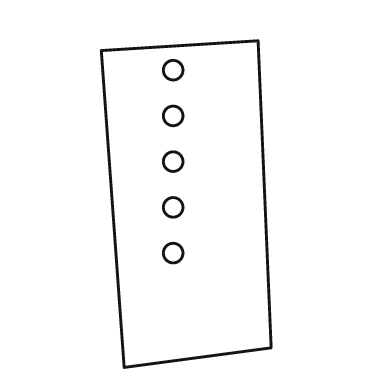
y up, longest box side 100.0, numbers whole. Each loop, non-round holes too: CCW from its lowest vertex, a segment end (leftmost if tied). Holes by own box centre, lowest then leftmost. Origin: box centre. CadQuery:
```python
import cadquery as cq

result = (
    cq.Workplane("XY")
    .moveTo(-19.0, -50.0)
    .lineTo(26.0, -44.0)
    .lineTo(22.0, 50.0)
    .lineTo(-26.0, 47.0)
    .close()
    .moveTo(-4.0, -15.0)
    .circle(3.0)
    .moveTo(-4.0, -1.0)
    .circle(3.0)
    .moveTo(-4.0, 13.0)
    .circle(3.0)
    .moveTo(-4.0, 27.0)
    .circle(3.0)
    .moveTo(-4.0, 41.0)
    .circle(3.0)
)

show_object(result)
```